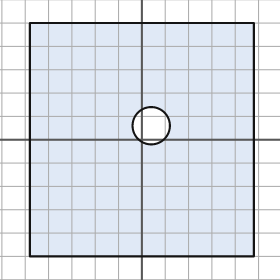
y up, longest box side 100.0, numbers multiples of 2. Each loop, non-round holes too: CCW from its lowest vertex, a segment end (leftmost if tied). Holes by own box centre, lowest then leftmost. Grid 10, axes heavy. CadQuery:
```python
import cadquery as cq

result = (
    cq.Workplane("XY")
    .moveTo(-48.0, -50.0)
    .lineTo(48.0, -50.0)
    .lineTo(48.0, 50.0)
    .lineTo(-48.0, 50.0)
    .close()
    .moveTo(4.0, 6.0)
    .circle(8.0)
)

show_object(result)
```